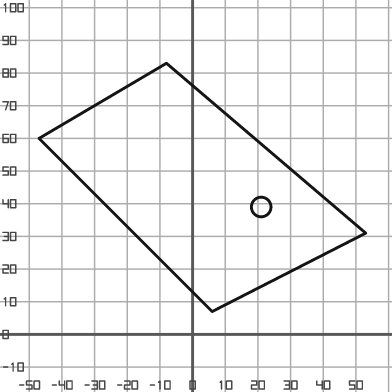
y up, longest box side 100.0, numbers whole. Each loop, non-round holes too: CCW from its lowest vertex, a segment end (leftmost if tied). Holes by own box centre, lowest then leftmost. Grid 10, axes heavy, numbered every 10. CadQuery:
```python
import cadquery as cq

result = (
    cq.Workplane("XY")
    .moveTo(6.0, 7.0)
    .lineTo(53.0, 31.0)
    .lineTo(-8.0, 83.0)
    .lineTo(-47.0, 60.0)
    .close()
    .moveTo(21.0, 39.0)
    .circle(3.0)
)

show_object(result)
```